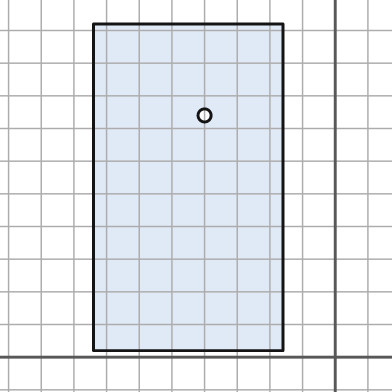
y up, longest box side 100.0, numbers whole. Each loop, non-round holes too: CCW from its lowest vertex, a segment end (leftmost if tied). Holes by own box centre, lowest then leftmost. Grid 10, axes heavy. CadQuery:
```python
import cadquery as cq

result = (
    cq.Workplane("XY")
    .moveTo(-74.0, 2.0)
    .lineTo(-16.0, 2.0)
    .lineTo(-16.0, 102.0)
    .lineTo(-74.0, 102.0)
    .close()
    .moveTo(-40.0, 74.0)
    .circle(2.0)
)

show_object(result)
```